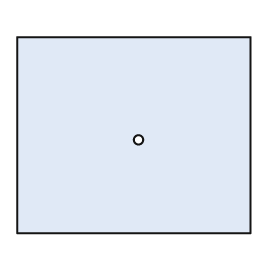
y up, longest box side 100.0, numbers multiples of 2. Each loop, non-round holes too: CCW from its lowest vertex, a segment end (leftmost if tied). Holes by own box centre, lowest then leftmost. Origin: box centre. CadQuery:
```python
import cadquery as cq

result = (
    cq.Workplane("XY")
    .moveTo(-50.0, -42.0)
    .lineTo(50.0, -42.0)
    .lineTo(50.0, 42.0)
    .lineTo(-50.0, 42.0)
    .close()
    .moveTo(2.0, -2.0)
    .circle(2.0)
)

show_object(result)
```